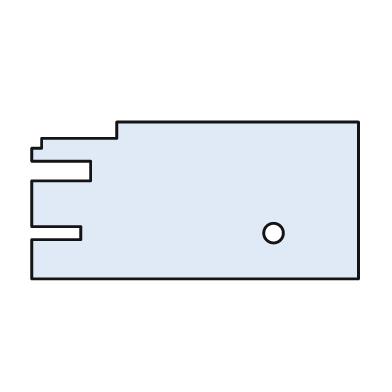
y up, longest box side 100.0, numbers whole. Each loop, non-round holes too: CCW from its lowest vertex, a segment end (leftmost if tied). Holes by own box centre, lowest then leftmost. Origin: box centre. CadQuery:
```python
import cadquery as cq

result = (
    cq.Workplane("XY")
    .moveTo(-50.0, -24.0)
    .lineTo(50.0, -24.0)
    .lineTo(50.0, 24.0)
    .lineTo(-24.0, 24.0)
    .lineTo(-24.0, 19.0)
    .lineTo(-47.0, 19.0)
    .lineTo(-47.0, 16.0)
    .lineTo(-50.0, 16.0)
    .lineTo(-50.0, 12.0)
    .lineTo(-32.0, 12.0)
    .lineTo(-32.0, 6.0)
    .lineTo(-50.0, 6.0)
    .lineTo(-50.0, -8.0)
    .lineTo(-35.0, -8.0)
    .lineTo(-35.0, -12.0)
    .lineTo(-50.0, -12.0)
    .close()
    .moveTo(24.0, -10.0)
    .circle(3.0)
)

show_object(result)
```